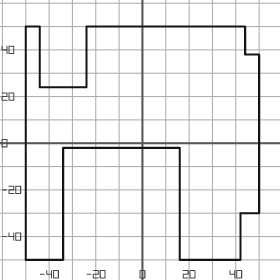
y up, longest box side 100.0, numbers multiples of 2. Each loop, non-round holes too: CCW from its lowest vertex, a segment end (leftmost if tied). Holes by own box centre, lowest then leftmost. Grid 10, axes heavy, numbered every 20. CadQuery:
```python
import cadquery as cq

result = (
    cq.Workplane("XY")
    .moveTo(-50.0, -50.0)
    .lineTo(-34.0, -50.0)
    .lineTo(-34.0, -2.0)
    .lineTo(16.0, -2.0)
    .lineTo(16.0, -50.0)
    .lineTo(42.0, -50.0)
    .lineTo(42.0, -30.0)
    .lineTo(50.0, -30.0)
    .lineTo(50.0, 38.0)
    .lineTo(44.0, 38.0)
    .lineTo(44.0, 50.0)
    .lineTo(-24.0, 50.0)
    .lineTo(-24.0, 24.0)
    .lineTo(-44.0, 24.0)
    .lineTo(-44.0, 50.0)
    .lineTo(-50.0, 50.0)
    .close()
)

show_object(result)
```